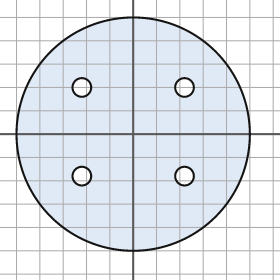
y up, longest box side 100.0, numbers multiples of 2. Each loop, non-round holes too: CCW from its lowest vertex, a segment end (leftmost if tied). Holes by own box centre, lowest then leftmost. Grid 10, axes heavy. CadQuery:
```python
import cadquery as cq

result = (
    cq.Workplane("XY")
    .moveTo(0.0, 0.0)
    .circle(50.0)
    .moveTo(-22.0, -18.0)
    .circle(4.0)
    .moveTo(22.0, -18.0)
    .circle(4.0)
    .moveTo(-22.0, 20.0)
    .circle(4.0)
    .moveTo(22.0, 20.0)
    .circle(4.0)
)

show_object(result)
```